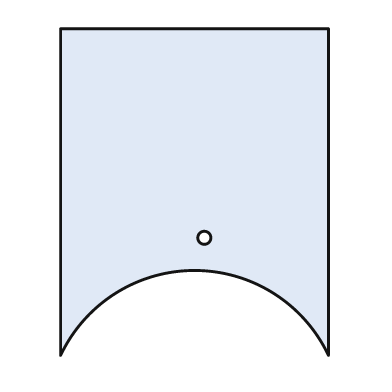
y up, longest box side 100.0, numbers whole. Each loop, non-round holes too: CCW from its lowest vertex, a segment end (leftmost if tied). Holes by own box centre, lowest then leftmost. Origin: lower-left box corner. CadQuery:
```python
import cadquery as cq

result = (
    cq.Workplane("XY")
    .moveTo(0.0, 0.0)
    .threePointArc((41.0, 26.0), (82.0, 0.0))
    .lineTo(82.0, 100.0)
    .lineTo(0.0, 100.0)
    .close()
    .moveTo(44.0, 36.0)
    .circle(2.0)
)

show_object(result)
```